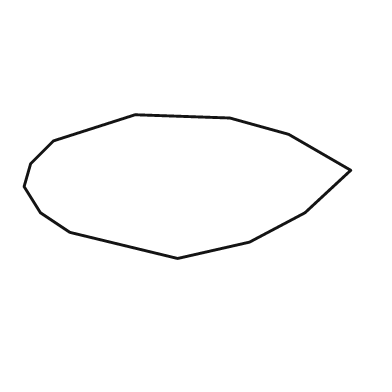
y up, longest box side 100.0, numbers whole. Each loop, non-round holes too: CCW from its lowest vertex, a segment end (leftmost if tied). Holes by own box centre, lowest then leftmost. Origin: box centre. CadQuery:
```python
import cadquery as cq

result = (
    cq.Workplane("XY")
    .moveTo(-3.0, -22.0)
    .lineTo(19.0, -17.0)
    .lineTo(36.0, -8.0)
    .lineTo(50.0, 5.0)
    .lineTo(31.0, 16.0)
    .lineTo(13.0, 21.0)
    .lineTo(-16.0, 22.0)
    .lineTo(-41.0, 14.0)
    .lineTo(-48.0, 7.0)
    .lineTo(-50.0, 0.0)
    .lineTo(-45.0, -8.0)
    .lineTo(-36.0, -14.0)
    .close()
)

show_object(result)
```